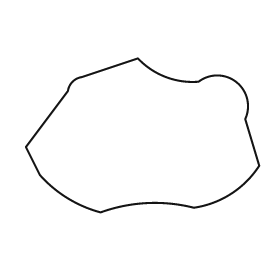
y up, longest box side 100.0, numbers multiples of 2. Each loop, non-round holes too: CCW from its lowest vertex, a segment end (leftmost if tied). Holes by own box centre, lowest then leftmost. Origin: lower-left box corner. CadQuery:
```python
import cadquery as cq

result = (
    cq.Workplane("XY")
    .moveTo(32.0, 0.0)
    .threePointArc((52.0, 4.0), (72.0, 2.0))
    .threePointArc((88.0, 8.0), (100.0, 20.0))
    .lineTo(94.0, 40.0)
    .threePointArc((90.0, 56.0), (74.0, 56.0))
    .threePointArc((60.0, 58.0), (48.0, 66.0))
    .lineTo(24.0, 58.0)
    .threePointArc((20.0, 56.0), (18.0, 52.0))
    .lineTo(0.0, 28.0)
    .lineTo(6.0, 16.0)
    .threePointArc((18.0, 6.0), (32.0, 0.0))
    .close()
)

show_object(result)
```